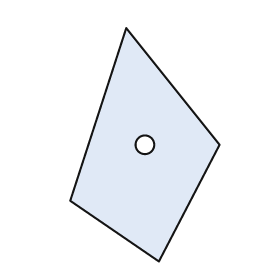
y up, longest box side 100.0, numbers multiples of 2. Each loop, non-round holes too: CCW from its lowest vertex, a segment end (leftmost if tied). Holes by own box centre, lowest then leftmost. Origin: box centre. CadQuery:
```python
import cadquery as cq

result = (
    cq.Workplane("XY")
    .moveTo(6.0, -50.0)
    .lineTo(32.0, 0.0)
    .lineTo(-8.0, 50.0)
    .lineTo(-32.0, -24.0)
    .close()
    .moveTo(0.0, 0.0)
    .circle(4.0)
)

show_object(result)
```